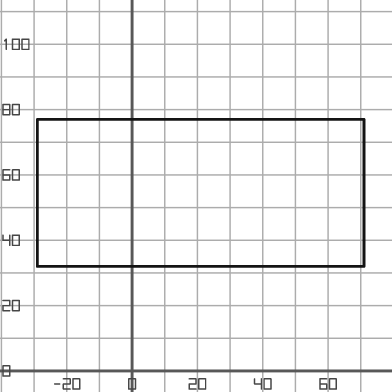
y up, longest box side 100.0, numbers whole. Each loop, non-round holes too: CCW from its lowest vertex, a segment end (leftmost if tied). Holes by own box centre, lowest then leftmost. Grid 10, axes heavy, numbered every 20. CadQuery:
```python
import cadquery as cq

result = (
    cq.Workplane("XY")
    .moveTo(-29.0, 32.0)
    .lineTo(71.0, 32.0)
    .lineTo(71.0, 77.0)
    .lineTo(-29.0, 77.0)
    .close()
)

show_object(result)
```